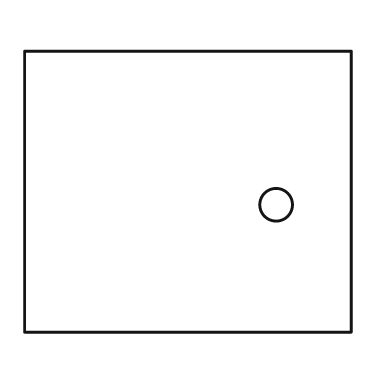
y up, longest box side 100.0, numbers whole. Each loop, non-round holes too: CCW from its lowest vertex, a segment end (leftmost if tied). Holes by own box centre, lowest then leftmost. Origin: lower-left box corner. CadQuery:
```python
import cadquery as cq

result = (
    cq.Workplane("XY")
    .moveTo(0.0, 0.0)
    .lineTo(100.0, 0.0)
    .lineTo(100.0, 86.0)
    .lineTo(0.0, 86.0)
    .close()
    .moveTo(77.0, 39.0)
    .circle(5.0)
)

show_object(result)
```